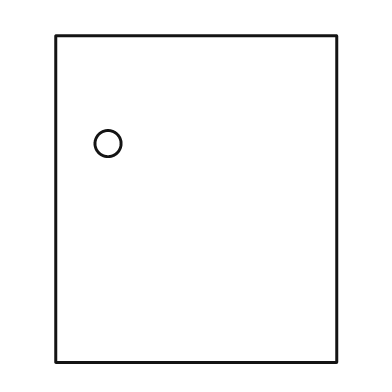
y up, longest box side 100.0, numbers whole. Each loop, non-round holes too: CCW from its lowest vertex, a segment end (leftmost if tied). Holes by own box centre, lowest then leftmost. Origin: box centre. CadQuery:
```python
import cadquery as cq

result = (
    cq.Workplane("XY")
    .moveTo(-43.0, -50.0)
    .lineTo(43.0, -50.0)
    .lineTo(43.0, 50.0)
    .lineTo(-43.0, 50.0)
    .close()
    .moveTo(-27.0, 17.0)
    .circle(4.0)
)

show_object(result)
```